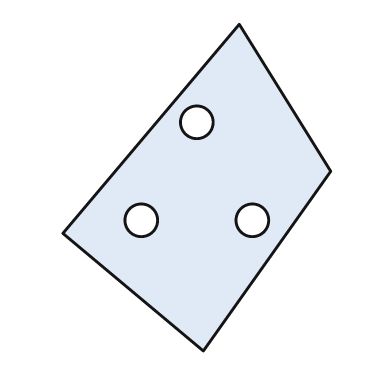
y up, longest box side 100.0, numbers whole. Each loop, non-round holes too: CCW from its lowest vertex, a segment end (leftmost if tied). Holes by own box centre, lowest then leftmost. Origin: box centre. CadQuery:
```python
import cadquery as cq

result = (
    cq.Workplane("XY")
    .moveTo(2.0, -50.0)
    .lineTo(41.0, 5.0)
    .lineTo(13.0, 50.0)
    .lineTo(-41.0, -14.0)
    .close()
    .moveTo(-17.0, -10.0)
    .circle(5.0)
    .moveTo(17.0, -10.0)
    .circle(5.0)
    .moveTo(0.0, 20.0)
    .circle(5.0)
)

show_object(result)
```